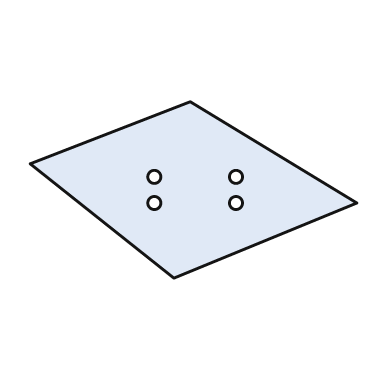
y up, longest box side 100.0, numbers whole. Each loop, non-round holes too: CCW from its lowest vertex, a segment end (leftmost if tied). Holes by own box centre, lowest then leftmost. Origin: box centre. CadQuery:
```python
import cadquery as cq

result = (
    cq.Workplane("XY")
    .moveTo(-6.0, -27.0)
    .lineTo(50.0, -4.0)
    .lineTo(-1.0, 27.0)
    .lineTo(-50.0, 8.0)
    .close()
    .moveTo(-12.0, -4.0)
    .circle(2.0)
    .moveTo(13.0, -4.0)
    .circle(2.0)
    .moveTo(-12.0, 4.0)
    .circle(2.0)
    .moveTo(13.0, 4.0)
    .circle(2.0)
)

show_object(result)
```